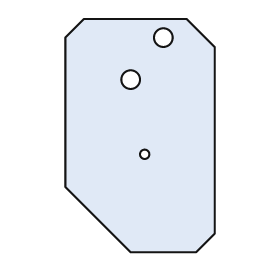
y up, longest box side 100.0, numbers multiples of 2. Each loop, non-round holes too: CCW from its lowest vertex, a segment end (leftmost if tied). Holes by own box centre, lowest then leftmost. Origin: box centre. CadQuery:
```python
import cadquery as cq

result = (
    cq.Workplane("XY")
    .moveTo(-4.0, -50.0)
    .lineTo(24.0, -50.0)
    .lineTo(32.0, -42.0)
    .lineTo(32.0, 38.0)
    .lineTo(20.0, 50.0)
    .lineTo(-24.0, 50.0)
    .lineTo(-32.0, 42.0)
    .lineTo(-32.0, -22.0)
    .close()
    .moveTo(2.0, -8.0)
    .circle(2.0)
    .moveTo(-4.0, 24.0)
    .circle(4.0)
    .moveTo(10.0, 42.0)
    .circle(4.0)
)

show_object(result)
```